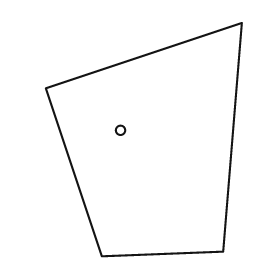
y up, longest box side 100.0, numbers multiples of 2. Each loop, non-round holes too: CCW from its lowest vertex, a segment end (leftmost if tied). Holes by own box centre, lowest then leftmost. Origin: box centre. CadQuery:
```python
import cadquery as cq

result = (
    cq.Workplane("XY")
    .moveTo(-18.0, -50.0)
    .lineTo(34.0, -48.0)
    .lineTo(42.0, 50.0)
    .lineTo(-42.0, 22.0)
    .close()
    .moveTo(-10.0, 4.0)
    .circle(2.0)
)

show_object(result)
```